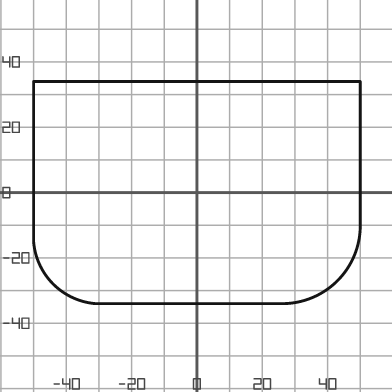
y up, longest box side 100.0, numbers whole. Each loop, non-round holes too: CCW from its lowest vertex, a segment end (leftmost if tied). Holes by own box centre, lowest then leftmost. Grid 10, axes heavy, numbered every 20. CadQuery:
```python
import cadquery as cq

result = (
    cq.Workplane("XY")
    .moveTo(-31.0, -34.0)
    .lineTo(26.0, -34.0)
    .threePointArc((43.0, -27.0), (50.0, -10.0))
    .lineTo(50.0, 34.0)
    .lineTo(-50.0, 34.0)
    .lineTo(-50.0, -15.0)
    .threePointArc((-44.0, -28.0), (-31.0, -34.0))
    .close()
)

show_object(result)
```